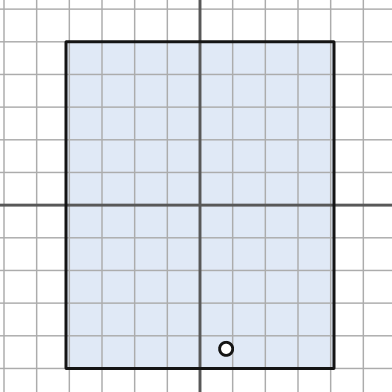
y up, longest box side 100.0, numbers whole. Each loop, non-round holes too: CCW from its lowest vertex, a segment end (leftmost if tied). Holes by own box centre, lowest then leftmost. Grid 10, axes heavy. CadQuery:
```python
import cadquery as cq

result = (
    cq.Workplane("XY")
    .moveTo(-41.0, -50.0)
    .lineTo(41.0, -50.0)
    .lineTo(41.0, 50.0)
    .lineTo(-41.0, 50.0)
    .close()
    .moveTo(8.0, -44.0)
    .circle(2.0)
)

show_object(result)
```